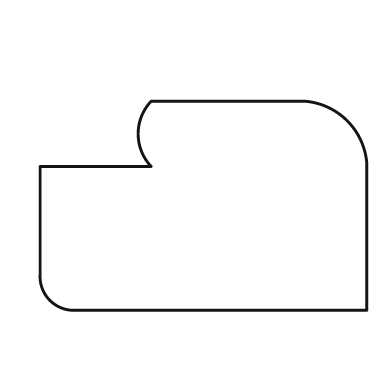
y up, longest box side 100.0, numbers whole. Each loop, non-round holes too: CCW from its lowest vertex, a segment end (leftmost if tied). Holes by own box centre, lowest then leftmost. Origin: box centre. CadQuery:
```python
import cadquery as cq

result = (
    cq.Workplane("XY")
    .moveTo(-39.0, -32.0)
    .lineTo(50.0, -32.0)
    .lineTo(50.0, 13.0)
    .threePointArc((44.0, 26.0), (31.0, 32.0))
    .lineTo(-16.0, 32.0)
    .threePointArc((-20.0, 22.0), (-16.0, 12.0))
    .lineTo(-50.0, 12.0)
    .lineTo(-50.0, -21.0)
    .threePointArc((-47.0, -29.0), (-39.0, -32.0))
    .close()
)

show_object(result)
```